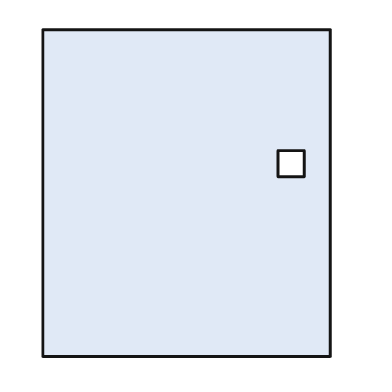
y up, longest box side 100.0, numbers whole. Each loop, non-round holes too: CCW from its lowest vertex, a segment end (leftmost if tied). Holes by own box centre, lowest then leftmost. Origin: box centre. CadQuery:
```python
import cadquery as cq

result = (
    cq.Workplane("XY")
    .moveTo(-44.0, -50.0)
    .lineTo(44.0, -50.0)
    .lineTo(44.0, 50.0)
    .lineTo(-44.0, 50.0)
    .close()
    .moveTo(28.0, 5.0)
    .lineTo(36.0, 5.0)
    .lineTo(36.0, 13.0)
    .lineTo(28.0, 13.0)
    .close()
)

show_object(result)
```